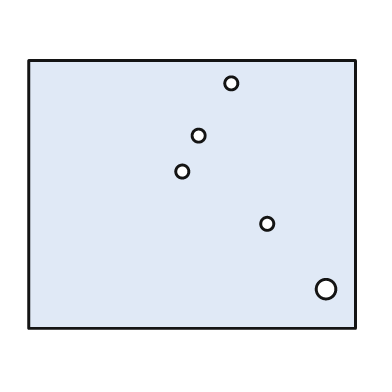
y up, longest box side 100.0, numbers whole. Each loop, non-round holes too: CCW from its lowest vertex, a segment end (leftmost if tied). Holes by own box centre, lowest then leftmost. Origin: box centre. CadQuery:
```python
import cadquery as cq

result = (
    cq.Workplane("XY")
    .moveTo(-50.0, -41.0)
    .lineTo(50.0, -41.0)
    .lineTo(50.0, 41.0)
    .lineTo(-50.0, 41.0)
    .close()
    .moveTo(41.0, -29.0)
    .circle(3.0)
    .moveTo(23.0, -9.0)
    .circle(2.0)
    .moveTo(-3.0, 7.0)
    .circle(2.0)
    .moveTo(2.0, 18.0)
    .circle(2.0)
    .moveTo(12.0, 34.0)
    .circle(2.0)
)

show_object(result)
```